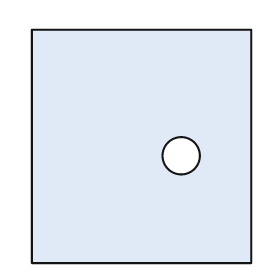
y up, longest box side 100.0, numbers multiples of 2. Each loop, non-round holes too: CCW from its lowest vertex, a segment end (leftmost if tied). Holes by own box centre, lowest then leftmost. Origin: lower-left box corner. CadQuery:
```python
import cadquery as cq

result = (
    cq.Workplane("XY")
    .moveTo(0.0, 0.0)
    .lineTo(94.0, 0.0)
    .lineTo(94.0, 100.0)
    .lineTo(0.0, 100.0)
    .close()
    .moveTo(64.0, 46.0)
    .circle(8.0)
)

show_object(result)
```